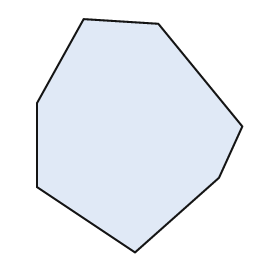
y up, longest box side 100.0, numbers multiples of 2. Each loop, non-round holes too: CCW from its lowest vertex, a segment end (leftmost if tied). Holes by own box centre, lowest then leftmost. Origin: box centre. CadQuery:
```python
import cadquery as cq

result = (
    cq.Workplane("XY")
    .moveTo(-2.0, -50.0)
    .lineTo(34.0, -18.0)
    .lineTo(44.0, 4.0)
    .lineTo(8.0, 48.0)
    .lineTo(-24.0, 50.0)
    .lineTo(-44.0, 14.0)
    .lineTo(-44.0, -22.0)
    .close()
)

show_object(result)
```